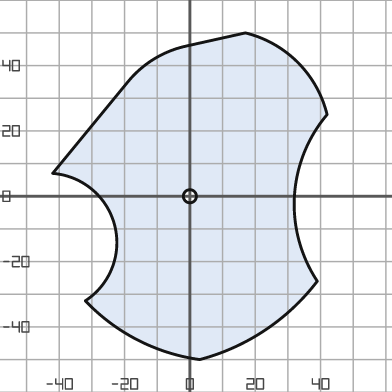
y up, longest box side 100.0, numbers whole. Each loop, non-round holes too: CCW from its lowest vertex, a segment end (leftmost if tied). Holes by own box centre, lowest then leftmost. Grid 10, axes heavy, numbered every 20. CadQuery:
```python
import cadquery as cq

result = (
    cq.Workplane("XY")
    .moveTo(3.0, -50.0)
    .threePointArc((23.0, -41.0), (39.0, -26.0))
    .threePointArc((32.0, 0.0), (42.0, 25.0))
    .threePointArc((33.0, 41.0), (17.0, 50.0))
    .lineTo(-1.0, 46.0)
    .threePointArc((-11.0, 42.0), (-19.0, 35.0))
    .lineTo(-42.0, 7.0)
    .threePointArc((-23.0, -9.0), (-32.0, -32.0))
    .threePointArc((-16.0, -44.0), (3.0, -50.0))
    .close()
    .moveTo(0.0, 0.0)
    .circle(2.0)
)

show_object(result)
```